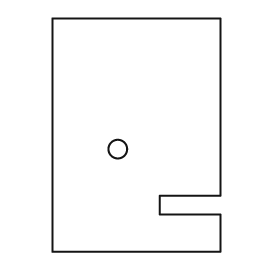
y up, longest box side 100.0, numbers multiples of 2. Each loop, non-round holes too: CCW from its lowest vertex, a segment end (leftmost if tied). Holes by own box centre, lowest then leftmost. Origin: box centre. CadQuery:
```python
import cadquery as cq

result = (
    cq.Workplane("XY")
    .moveTo(-36.0, -50.0)
    .lineTo(36.0, -50.0)
    .lineTo(36.0, -34.0)
    .lineTo(10.0, -34.0)
    .lineTo(10.0, -26.0)
    .lineTo(36.0, -26.0)
    .lineTo(36.0, 50.0)
    .lineTo(-36.0, 50.0)
    .close()
    .moveTo(-8.0, -6.0)
    .circle(4.0)
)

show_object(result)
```